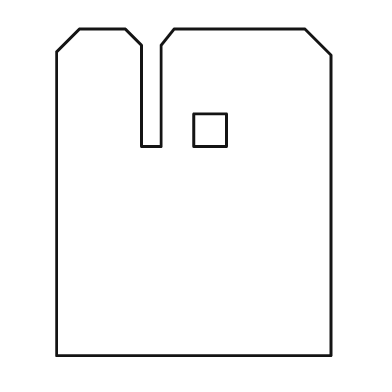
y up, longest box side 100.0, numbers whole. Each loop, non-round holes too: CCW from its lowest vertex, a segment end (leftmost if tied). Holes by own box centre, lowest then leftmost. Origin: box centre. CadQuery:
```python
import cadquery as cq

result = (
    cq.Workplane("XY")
    .moveTo(-42.0, -50.0)
    .lineTo(42.0, -50.0)
    .lineTo(42.0, 42.0)
    .lineTo(34.0, 50.0)
    .lineTo(-6.0, 50.0)
    .lineTo(-10.0, 45.0)
    .lineTo(-10.0, 14.0)
    .lineTo(-16.0, 14.0)
    .lineTo(-16.0, 45.0)
    .lineTo(-21.0, 50.0)
    .lineTo(-35.0, 50.0)
    .lineTo(-42.0, 43.0)
    .close()
    .moveTo(0.0, 14.0)
    .lineTo(10.0, 14.0)
    .lineTo(10.0, 24.0)
    .lineTo(0.0, 24.0)
    .close()
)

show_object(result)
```